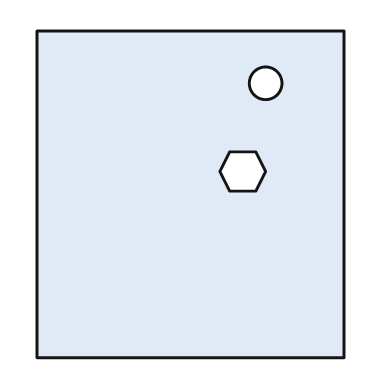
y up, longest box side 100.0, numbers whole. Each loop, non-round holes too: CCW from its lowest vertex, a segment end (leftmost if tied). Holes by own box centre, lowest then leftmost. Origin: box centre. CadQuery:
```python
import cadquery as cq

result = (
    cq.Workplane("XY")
    .moveTo(-47.0, -50.0)
    .lineTo(47.0, -50.0)
    .lineTo(47.0, 50.0)
    .lineTo(-47.0, 50.0)
    .close()
    .moveTo(12.0, 1.0)
    .lineTo(20.0, 1.0)
    .lineTo(23.0, 7.0)
    .lineTo(20.0, 13.0)
    .lineTo(12.0, 13.0)
    .lineTo(9.0, 7.0)
    .close()
    .moveTo(23.0, 34.0)
    .circle(5.0)
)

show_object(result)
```